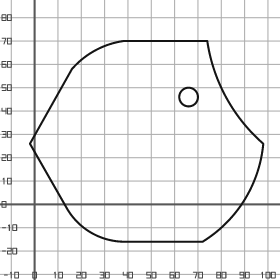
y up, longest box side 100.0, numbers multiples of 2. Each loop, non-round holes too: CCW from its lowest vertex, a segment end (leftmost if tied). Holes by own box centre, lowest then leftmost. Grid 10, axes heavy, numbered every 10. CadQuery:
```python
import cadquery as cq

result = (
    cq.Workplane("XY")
    .moveTo(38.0, -16.0)
    .lineTo(72.0, -16.0)
    .threePointArc((90.0, 2.0), (98.0, 26.0))
    .threePointArc((82.0, 46.0), (74.0, 70.0))
    .lineTo(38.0, 70.0)
    .threePointArc((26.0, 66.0), (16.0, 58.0))
    .lineTo(-2.0, 26.0)
    .lineTo(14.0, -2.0)
    .threePointArc((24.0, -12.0), (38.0, -16.0))
    .close()
    .moveTo(66.0, 46.0)
    .circle(4.0)
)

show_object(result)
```